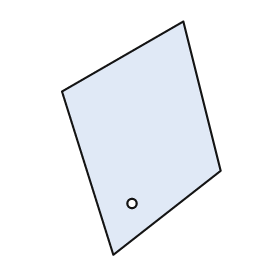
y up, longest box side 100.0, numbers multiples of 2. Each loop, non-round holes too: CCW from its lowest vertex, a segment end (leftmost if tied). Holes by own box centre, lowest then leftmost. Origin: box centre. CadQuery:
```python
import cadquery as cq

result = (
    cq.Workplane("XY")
    .moveTo(-12.0, -50.0)
    .lineTo(34.0, -14.0)
    .lineTo(18.0, 50.0)
    .lineTo(-34.0, 20.0)
    .close()
    .moveTo(-4.0, -28.0)
    .circle(2.0)
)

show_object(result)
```